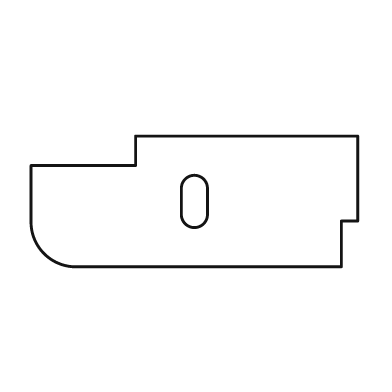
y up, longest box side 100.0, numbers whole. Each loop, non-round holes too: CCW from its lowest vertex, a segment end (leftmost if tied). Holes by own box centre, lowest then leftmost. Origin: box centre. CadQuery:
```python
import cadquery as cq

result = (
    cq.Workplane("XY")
    .moveTo(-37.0, -20.0)
    .lineTo(45.0, -20.0)
    .lineTo(45.0, -6.0)
    .lineTo(50.0, -6.0)
    .lineTo(50.0, 20.0)
    .lineTo(-18.0, 20.0)
    .lineTo(-18.0, 11.0)
    .lineTo(-50.0, 11.0)
    .lineTo(-50.0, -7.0)
    .threePointArc((-46.0, -16.0), (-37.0, -20.0))
    .close()
    .moveTo(-4.0, -4.0)
    .threePointArc((0.0, -8.0), (4.0, -4.0))
    .lineTo(4.0, 4.0)
    .threePointArc((0.0, 8.0), (-4.0, 4.0))
    .close()
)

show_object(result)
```